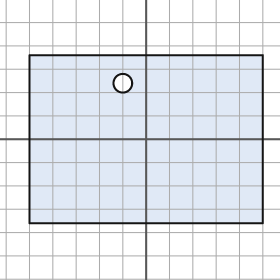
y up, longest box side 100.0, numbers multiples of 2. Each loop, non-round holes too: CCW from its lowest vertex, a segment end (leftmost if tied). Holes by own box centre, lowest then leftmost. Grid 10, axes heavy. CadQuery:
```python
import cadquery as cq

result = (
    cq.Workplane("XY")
    .moveTo(-50.0, -36.0)
    .lineTo(50.0, -36.0)
    .lineTo(50.0, 36.0)
    .lineTo(-50.0, 36.0)
    .close()
    .moveTo(-10.0, 24.0)
    .circle(4.0)
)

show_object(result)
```